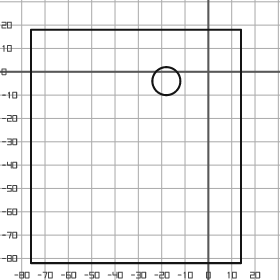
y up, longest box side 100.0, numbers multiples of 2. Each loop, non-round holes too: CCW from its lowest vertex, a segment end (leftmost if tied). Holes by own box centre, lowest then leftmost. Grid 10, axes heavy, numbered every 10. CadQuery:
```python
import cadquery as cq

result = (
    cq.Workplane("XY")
    .moveTo(-76.0, -82.0)
    .lineTo(14.0, -82.0)
    .lineTo(14.0, 18.0)
    .lineTo(-76.0, 18.0)
    .close()
    .moveTo(-18.0, -4.0)
    .circle(6.0)
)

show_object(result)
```